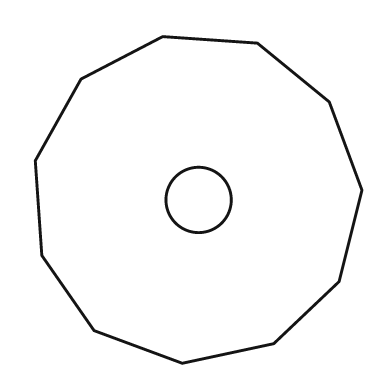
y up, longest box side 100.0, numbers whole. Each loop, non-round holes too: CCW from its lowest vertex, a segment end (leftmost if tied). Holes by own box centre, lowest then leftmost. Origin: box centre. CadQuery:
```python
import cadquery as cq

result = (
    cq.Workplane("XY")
    .moveTo(-5.0, -50.0)
    .lineTo(23.0, -44.0)
    .lineTo(43.0, -25.0)
    .lineTo(50.0, 3.0)
    .lineTo(40.0, 30.0)
    .lineTo(18.0, 48.0)
    .lineTo(-11.0, 50.0)
    .lineTo(-36.0, 37.0)
    .lineTo(-50.0, 12.0)
    .lineTo(-48.0, -17.0)
    .lineTo(-32.0, -40.0)
    .close()
    .moveTo(0.0, 0.0)
    .circle(10.0)
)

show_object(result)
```